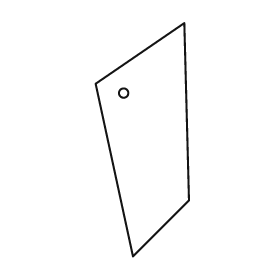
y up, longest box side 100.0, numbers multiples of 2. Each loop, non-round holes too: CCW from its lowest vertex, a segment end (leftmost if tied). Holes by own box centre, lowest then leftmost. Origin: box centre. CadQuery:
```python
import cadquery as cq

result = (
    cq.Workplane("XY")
    .moveTo(-4.0, -50.0)
    .lineTo(20.0, -26.0)
    .lineTo(18.0, 50.0)
    .lineTo(-20.0, 24.0)
    .close()
    .moveTo(-8.0, 20.0)
    .circle(2.0)
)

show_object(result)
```